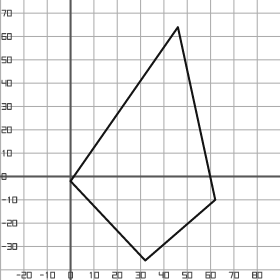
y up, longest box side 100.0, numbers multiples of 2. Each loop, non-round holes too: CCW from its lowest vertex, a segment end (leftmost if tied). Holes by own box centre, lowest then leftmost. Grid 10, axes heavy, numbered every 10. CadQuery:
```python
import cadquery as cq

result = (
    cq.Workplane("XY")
    .moveTo(32.0, -36.0)
    .lineTo(62.0, -10.0)
    .lineTo(46.0, 64.0)
    .lineTo(0.0, -2.0)
    .close()
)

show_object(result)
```